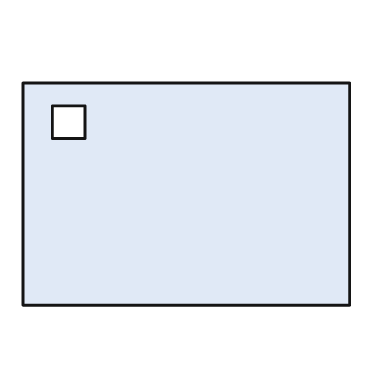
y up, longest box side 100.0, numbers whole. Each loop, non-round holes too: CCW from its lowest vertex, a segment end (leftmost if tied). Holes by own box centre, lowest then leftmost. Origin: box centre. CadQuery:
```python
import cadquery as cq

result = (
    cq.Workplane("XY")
    .moveTo(-50.0, -34.0)
    .lineTo(50.0, -34.0)
    .lineTo(50.0, 34.0)
    .lineTo(-50.0, 34.0)
    .close()
    .moveTo(-41.0, 17.0)
    .lineTo(-31.0, 17.0)
    .lineTo(-31.0, 27.0)
    .lineTo(-41.0, 27.0)
    .close()
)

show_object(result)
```